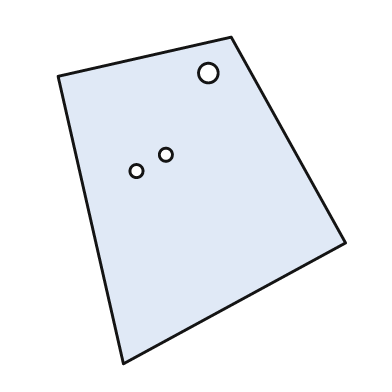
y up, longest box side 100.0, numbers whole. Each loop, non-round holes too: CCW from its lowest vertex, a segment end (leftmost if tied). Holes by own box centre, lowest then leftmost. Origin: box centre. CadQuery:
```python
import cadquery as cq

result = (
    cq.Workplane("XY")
    .moveTo(-24.0, -50.0)
    .lineTo(44.0, -13.0)
    .lineTo(9.0, 50.0)
    .lineTo(-44.0, 38.0)
    .close()
    .moveTo(-20.0, 9.0)
    .circle(2.0)
    .moveTo(-11.0, 14.0)
    .circle(2.0)
    .moveTo(2.0, 39.0)
    .circle(3.0)
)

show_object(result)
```